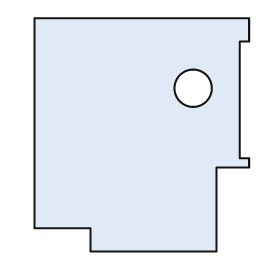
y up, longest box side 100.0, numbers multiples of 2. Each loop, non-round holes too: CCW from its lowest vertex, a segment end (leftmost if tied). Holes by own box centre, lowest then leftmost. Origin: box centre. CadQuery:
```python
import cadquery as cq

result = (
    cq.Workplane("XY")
    .moveTo(-22.0, -50.0)
    .lineTo(32.0, -50.0)
    .lineTo(32.0, -14.0)
    .lineTo(46.0, -14.0)
    .lineTo(46.0, -10.0)
    .lineTo(42.0, -10.0)
    .lineTo(42.0, 40.0)
    .lineTo(46.0, 40.0)
    .lineTo(46.0, 50.0)
    .lineTo(-46.0, 50.0)
    .lineTo(-46.0, -40.0)
    .lineTo(-22.0, -40.0)
    .close()
    .moveTo(22.0, 20.0)
    .circle(8.0)
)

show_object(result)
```